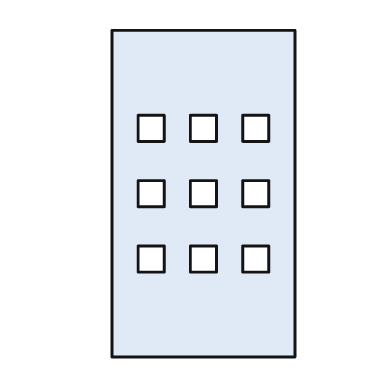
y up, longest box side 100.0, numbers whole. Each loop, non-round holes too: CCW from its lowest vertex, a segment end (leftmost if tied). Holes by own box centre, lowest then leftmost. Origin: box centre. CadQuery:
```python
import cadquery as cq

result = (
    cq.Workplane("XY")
    .moveTo(-28.0, -50.0)
    .lineTo(28.0, -50.0)
    .lineTo(28.0, 50.0)
    .lineTo(-28.0, 50.0)
    .close()
    .moveTo(-20.0, -24.0)
    .lineTo(-12.0, -24.0)
    .lineTo(-12.0, -16.0)
    .lineTo(-20.0, -16.0)
    .close()
    .moveTo(-4.0, -24.0)
    .lineTo(4.0, -24.0)
    .lineTo(4.0, -16.0)
    .lineTo(-4.0, -16.0)
    .close()
    .moveTo(12.0, -24.0)
    .lineTo(20.0, -24.0)
    .lineTo(20.0, -16.0)
    .lineTo(12.0, -16.0)
    .close()
    .moveTo(-20.0, -4.0)
    .lineTo(-12.0, -4.0)
    .lineTo(-12.0, 4.0)
    .lineTo(-20.0, 4.0)
    .close()
    .moveTo(-4.0, -4.0)
    .lineTo(4.0, -4.0)
    .lineTo(4.0, 4.0)
    .lineTo(-4.0, 4.0)
    .close()
    .moveTo(12.0, -4.0)
    .lineTo(20.0, -4.0)
    .lineTo(20.0, 4.0)
    .lineTo(12.0, 4.0)
    .close()
    .moveTo(-20.0, 16.0)
    .lineTo(-12.0, 16.0)
    .lineTo(-12.0, 24.0)
    .lineTo(-20.0, 24.0)
    .close()
    .moveTo(-4.0, 16.0)
    .lineTo(4.0, 16.0)
    .lineTo(4.0, 24.0)
    .lineTo(-4.0, 24.0)
    .close()
    .moveTo(12.0, 16.0)
    .lineTo(20.0, 16.0)
    .lineTo(20.0, 24.0)
    .lineTo(12.0, 24.0)
    .close()
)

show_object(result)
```